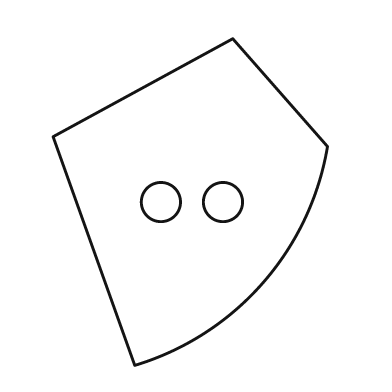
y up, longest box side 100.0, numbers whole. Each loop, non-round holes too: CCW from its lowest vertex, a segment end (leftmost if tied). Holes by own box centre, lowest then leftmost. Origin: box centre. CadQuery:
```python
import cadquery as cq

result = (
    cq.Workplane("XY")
    .moveTo(-17.0, -50.0)
    .threePointArc((22.0, -25.0), (42.0, 17.0))
    .lineTo(13.0, 50.0)
    .lineTo(-42.0, 20.0)
    .close()
    .moveTo(-9.0, 0.0)
    .circle(6.0)
    .moveTo(10.0, 0.0)
    .circle(6.0)
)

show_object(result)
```